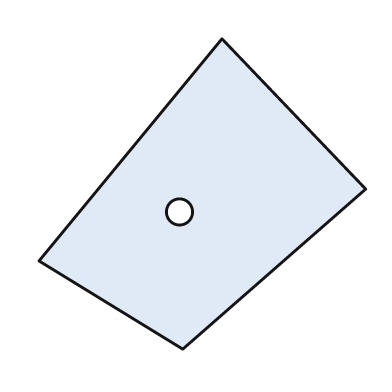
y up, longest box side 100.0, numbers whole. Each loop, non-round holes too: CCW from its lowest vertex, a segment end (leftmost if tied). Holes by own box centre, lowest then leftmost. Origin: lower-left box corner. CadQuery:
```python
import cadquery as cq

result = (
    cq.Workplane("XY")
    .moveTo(44.0, 0.0)
    .lineTo(100.0, 49.0)
    .lineTo(56.0, 95.0)
    .lineTo(0.0, 27.0)
    .close()
    .moveTo(43.0, 42.0)
    .circle(4.0)
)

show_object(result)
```